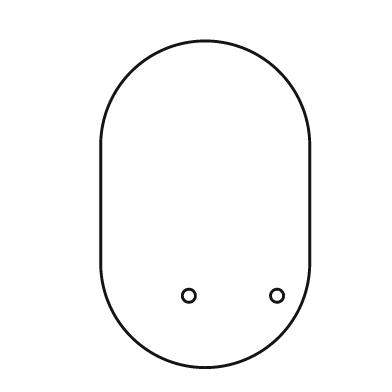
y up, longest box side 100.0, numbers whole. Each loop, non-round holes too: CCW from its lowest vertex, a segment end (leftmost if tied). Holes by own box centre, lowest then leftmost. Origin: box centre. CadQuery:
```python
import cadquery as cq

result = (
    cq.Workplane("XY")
    .moveTo(-32.0, -18.0)
    .threePointArc((0.0, -50.0), (32.0, -18.0))
    .lineTo(32.0, 18.0)
    .threePointArc((0.0, 50.0), (-32.0, 18.0))
    .close()
    .moveTo(-5.0, -28.0)
    .circle(2.0)
    .moveTo(22.0, -28.0)
    .circle(2.0)
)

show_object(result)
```